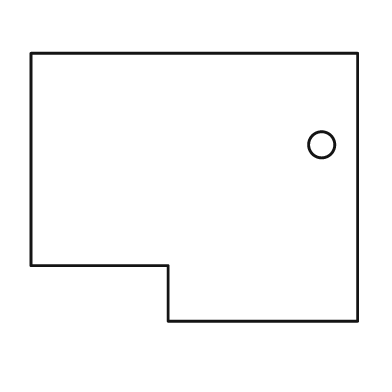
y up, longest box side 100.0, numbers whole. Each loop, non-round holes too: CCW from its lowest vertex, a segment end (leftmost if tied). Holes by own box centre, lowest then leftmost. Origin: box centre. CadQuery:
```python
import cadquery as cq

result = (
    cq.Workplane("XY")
    .moveTo(-8.0, -41.0)
    .lineTo(50.0, -41.0)
    .lineTo(50.0, 41.0)
    .lineTo(-50.0, 41.0)
    .lineTo(-50.0, -24.0)
    .lineTo(-8.0, -24.0)
    .close()
    .moveTo(39.0, 13.0)
    .circle(4.0)
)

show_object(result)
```